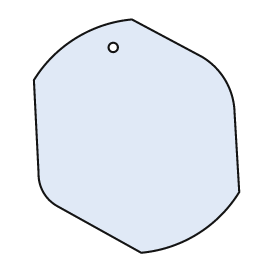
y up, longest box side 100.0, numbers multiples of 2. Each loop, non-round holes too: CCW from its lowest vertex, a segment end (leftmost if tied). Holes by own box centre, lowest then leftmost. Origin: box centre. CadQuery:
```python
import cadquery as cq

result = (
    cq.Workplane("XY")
    .moveTo(2.0, -50.0)
    .threePointArc((26.0, -42.0), (44.0, -24.0))
    .lineTo(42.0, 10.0)
    .threePointArc((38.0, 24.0), (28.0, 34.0))
    .lineTo(-2.0, 50.0)
    .threePointArc((-26.0, 42.0), (-44.0, 24.0))
    .lineTo(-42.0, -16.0)
    .threePointArc((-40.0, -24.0), (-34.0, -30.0))
    .close()
    .moveTo(-10.0, 38.0)
    .circle(2.0)
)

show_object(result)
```